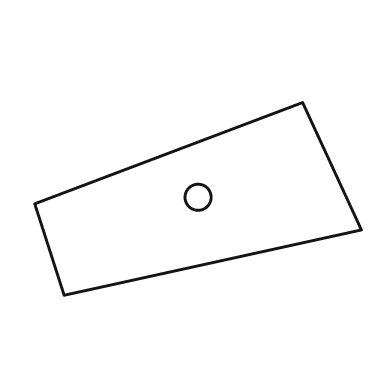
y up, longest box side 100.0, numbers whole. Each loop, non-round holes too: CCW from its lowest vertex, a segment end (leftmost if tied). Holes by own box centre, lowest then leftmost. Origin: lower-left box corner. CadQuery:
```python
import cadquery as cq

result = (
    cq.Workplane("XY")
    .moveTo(9.0, 0.0)
    .lineTo(100.0, 20.0)
    .lineTo(82.0, 59.0)
    .lineTo(0.0, 28.0)
    .close()
    .moveTo(50.0, 30.0)
    .circle(4.0)
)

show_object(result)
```